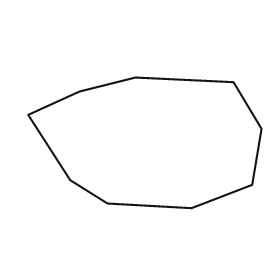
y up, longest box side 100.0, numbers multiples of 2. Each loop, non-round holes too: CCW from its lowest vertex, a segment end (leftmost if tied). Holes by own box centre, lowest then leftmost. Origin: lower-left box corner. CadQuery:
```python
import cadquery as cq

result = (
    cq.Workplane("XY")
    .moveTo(70.0, 0.0)
    .lineTo(96.0, 10.0)
    .lineTo(100.0, 34.0)
    .lineTo(88.0, 54.0)
    .lineTo(46.0, 56.0)
    .lineTo(22.0, 50.0)
    .lineTo(0.0, 40.0)
    .lineTo(18.0, 12.0)
    .lineTo(34.0, 2.0)
    .close()
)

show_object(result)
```